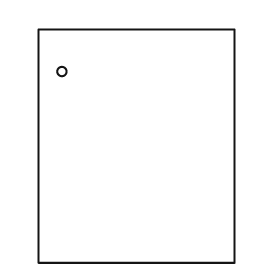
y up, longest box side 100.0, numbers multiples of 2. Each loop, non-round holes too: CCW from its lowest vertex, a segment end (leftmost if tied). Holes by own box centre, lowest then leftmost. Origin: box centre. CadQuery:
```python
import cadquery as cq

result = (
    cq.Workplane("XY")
    .moveTo(-42.0, -50.0)
    .lineTo(42.0, -50.0)
    .lineTo(42.0, 50.0)
    .lineTo(-42.0, 50.0)
    .close()
    .moveTo(-32.0, 32.0)
    .circle(2.0)
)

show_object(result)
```